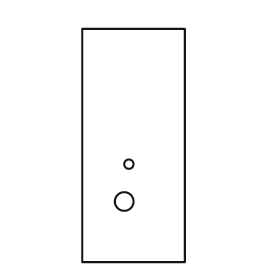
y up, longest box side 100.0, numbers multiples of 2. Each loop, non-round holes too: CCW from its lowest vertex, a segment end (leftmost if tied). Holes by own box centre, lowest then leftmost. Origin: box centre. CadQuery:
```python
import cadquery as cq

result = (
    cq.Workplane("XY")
    .moveTo(-22.0, -50.0)
    .lineTo(22.0, -50.0)
    .lineTo(22.0, 50.0)
    .lineTo(-22.0, 50.0)
    .close()
    .moveTo(-4.0, -24.0)
    .circle(4.0)
    .moveTo(-2.0, -8.0)
    .circle(2.0)
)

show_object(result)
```